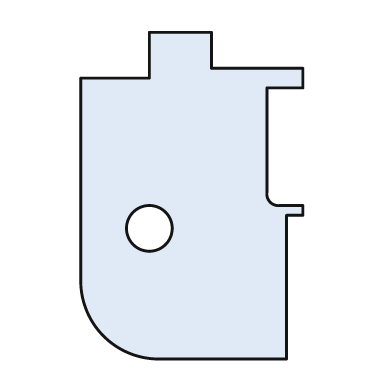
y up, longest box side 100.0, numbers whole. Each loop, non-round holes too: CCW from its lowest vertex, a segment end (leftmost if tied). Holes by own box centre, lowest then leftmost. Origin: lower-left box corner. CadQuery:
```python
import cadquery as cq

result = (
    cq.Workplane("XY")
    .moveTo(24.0, 0.0)
    .lineTo(63.0, 0.0)
    .lineTo(63.0, 44.0)
    .lineTo(68.0, 44.0)
    .lineTo(68.0, 47.0)
    .lineTo(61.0, 47.0)
    .threePointArc((58.0, 48.0), (57.0, 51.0))
    .lineTo(57.0, 83.0)
    .lineTo(68.0, 83.0)
    .lineTo(68.0, 89.0)
    .lineTo(40.0, 89.0)
    .lineTo(40.0, 100.0)
    .lineTo(21.0, 100.0)
    .lineTo(21.0, 86.0)
    .lineTo(0.0, 86.0)
    .lineTo(0.0, 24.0)
    .threePointArc((7.0, 7.0), (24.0, 0.0))
    .close()
    .moveTo(21.0, 40.0)
    .circle(7.0)
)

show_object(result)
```